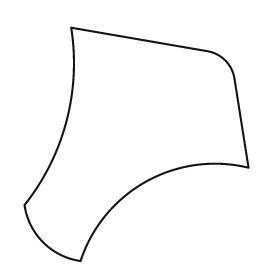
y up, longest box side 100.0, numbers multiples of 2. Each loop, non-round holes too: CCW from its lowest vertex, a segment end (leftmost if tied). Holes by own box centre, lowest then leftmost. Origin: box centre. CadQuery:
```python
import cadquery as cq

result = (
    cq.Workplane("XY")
    .moveTo(-24.0, -50.0)
    .threePointArc((4.0, -16.0), (48.0, -10.0))
    .lineTo(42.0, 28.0)
    .threePointArc((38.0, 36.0), (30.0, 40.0))
    .lineTo(-28.0, 50.0)
    .threePointArc((-30.0, 10.0), (-48.0, -26.0))
    .threePointArc((-40.0, -42.0), (-24.0, -50.0))
    .close()
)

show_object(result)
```